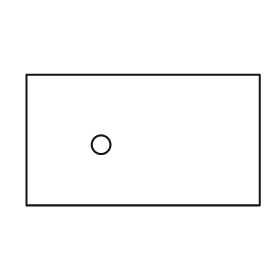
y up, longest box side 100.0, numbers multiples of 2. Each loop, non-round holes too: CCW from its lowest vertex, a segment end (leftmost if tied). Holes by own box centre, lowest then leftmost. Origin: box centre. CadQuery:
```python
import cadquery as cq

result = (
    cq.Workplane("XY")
    .moveTo(-50.0, -28.0)
    .lineTo(50.0, -28.0)
    .lineTo(50.0, 28.0)
    .lineTo(-50.0, 28.0)
    .close()
    .moveTo(-18.0, -2.0)
    .circle(4.0)
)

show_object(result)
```